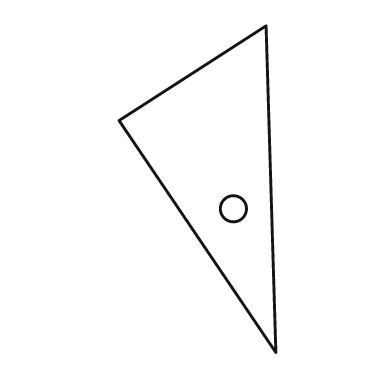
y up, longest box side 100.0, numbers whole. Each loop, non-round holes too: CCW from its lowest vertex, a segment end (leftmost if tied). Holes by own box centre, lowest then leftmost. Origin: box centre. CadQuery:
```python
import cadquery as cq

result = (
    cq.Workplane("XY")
    .moveTo(24.0, -50.0)
    .lineTo(21.0, 50.0)
    .lineTo(-24.0, 21.0)
    .close()
    .moveTo(11.0, -6.0)
    .circle(4.0)
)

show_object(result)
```